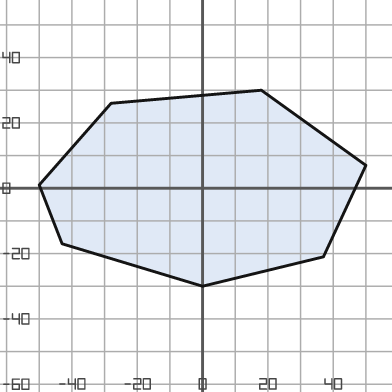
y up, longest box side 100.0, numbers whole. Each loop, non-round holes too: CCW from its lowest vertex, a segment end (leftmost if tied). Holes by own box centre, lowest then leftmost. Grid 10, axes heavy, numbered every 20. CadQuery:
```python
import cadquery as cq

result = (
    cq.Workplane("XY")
    .moveTo(0.0, -30.0)
    .lineTo(37.0, -21.0)
    .lineTo(50.0, 7.0)
    .lineTo(18.0, 30.0)
    .lineTo(-28.0, 26.0)
    .lineTo(-50.0, 1.0)
    .lineTo(-43.0, -17.0)
    .close()
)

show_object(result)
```